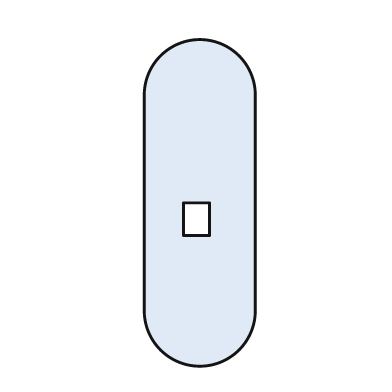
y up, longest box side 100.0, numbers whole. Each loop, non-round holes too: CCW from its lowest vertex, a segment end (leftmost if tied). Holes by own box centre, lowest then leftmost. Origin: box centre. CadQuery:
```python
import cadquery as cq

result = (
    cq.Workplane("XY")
    .moveTo(-17.0, -33.0)
    .threePointArc((0.0, -50.0), (17.0, -33.0))
    .lineTo(17.0, 33.0)
    .threePointArc((0.0, 50.0), (-17.0, 33.0))
    .close()
    .moveTo(-5.0, -10.0)
    .lineTo(3.0, -10.0)
    .lineTo(3.0, 0.0)
    .lineTo(-5.0, 0.0)
    .close()
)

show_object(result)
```